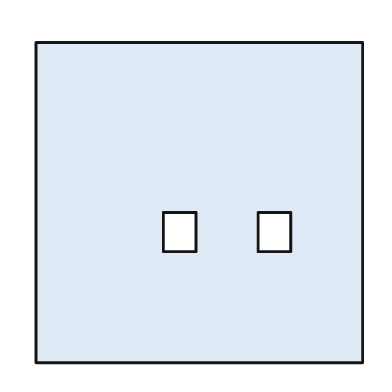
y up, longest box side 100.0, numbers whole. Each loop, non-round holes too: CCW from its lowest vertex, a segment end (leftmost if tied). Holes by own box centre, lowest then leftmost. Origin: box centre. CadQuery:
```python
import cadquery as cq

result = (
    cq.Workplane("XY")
    .moveTo(-50.0, -49.0)
    .lineTo(50.0, -49.0)
    .lineTo(50.0, 49.0)
    .lineTo(-50.0, 49.0)
    .close()
    .moveTo(-11.0, -15.0)
    .lineTo(-1.0, -15.0)
    .lineTo(-1.0, -3.0)
    .lineTo(-11.0, -3.0)
    .close()
    .moveTo(18.0, -15.0)
    .lineTo(28.0, -15.0)
    .lineTo(28.0, -3.0)
    .lineTo(18.0, -3.0)
    .close()
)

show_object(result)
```